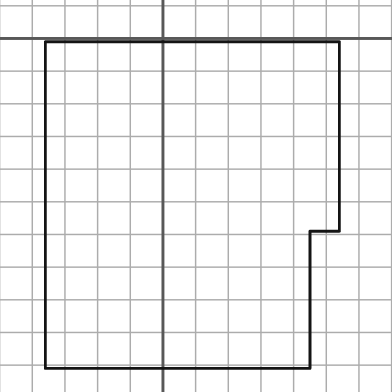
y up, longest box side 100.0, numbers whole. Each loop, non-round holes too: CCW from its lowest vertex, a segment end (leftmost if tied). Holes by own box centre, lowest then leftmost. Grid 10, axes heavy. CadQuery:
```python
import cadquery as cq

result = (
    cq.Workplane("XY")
    .moveTo(-36.0, -101.0)
    .lineTo(45.0, -101.0)
    .lineTo(45.0, -59.0)
    .lineTo(54.0, -59.0)
    .lineTo(54.0, -1.0)
    .lineTo(-36.0, -1.0)
    .close()
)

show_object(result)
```